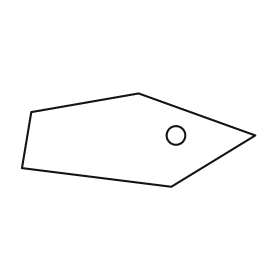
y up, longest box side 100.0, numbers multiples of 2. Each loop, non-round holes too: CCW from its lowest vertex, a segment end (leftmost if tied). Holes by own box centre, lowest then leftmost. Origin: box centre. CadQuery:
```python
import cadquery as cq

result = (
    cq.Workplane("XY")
    .moveTo(14.0, -20.0)
    .lineTo(50.0, 2.0)
    .lineTo(0.0, 20.0)
    .lineTo(-46.0, 12.0)
    .lineTo(-50.0, -12.0)
    .close()
    .moveTo(16.0, 2.0)
    .circle(4.0)
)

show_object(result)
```